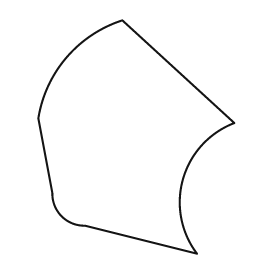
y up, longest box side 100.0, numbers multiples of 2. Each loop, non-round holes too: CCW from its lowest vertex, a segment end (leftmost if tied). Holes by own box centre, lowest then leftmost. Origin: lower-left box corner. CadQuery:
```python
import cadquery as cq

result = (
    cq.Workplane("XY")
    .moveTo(68.0, 0.0)
    .threePointArc((62.0, 32.0), (84.0, 56.0))
    .lineTo(36.0, 100.0)
    .threePointArc((12.0, 84.0), (0.0, 58.0))
    .lineTo(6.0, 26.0)
    .threePointArc((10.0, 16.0), (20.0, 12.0))
    .close()
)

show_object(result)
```